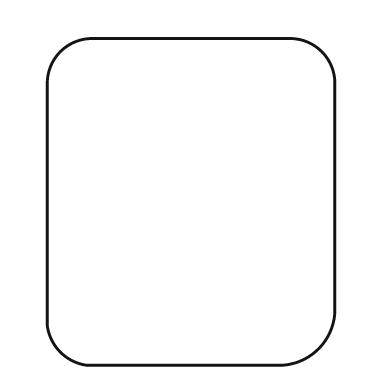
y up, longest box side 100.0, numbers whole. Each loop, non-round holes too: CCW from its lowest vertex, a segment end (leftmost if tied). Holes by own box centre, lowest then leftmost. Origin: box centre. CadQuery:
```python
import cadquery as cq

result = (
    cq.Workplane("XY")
    .moveTo(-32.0, -50.0)
    .lineTo(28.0, -50.0)
    .threePointArc((39.0, -45.0), (44.0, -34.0))
    .lineTo(44.0, 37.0)
    .threePointArc((40.0, 46.0), (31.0, 50.0))
    .lineTo(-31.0, 50.0)
    .threePointArc((-40.0, 46.0), (-44.0, 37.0))
    .lineTo(-44.0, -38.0)
    .threePointArc((-40.0, -46.0), (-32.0, -50.0))
    .close()
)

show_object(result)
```